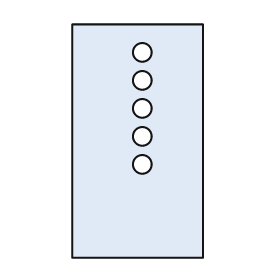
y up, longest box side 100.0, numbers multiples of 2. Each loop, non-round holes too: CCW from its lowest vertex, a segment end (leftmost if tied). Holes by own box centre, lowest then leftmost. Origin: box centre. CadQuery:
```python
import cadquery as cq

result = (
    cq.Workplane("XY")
    .moveTo(-28.0, -50.0)
    .lineTo(28.0, -50.0)
    .lineTo(28.0, 50.0)
    .lineTo(-28.0, 50.0)
    .close()
    .moveTo(2.0, -10.0)
    .circle(4.0)
    .moveTo(2.0, 2.0)
    .circle(4.0)
    .moveTo(2.0, 14.0)
    .circle(4.0)
    .moveTo(2.0, 26.0)
    .circle(4.0)
    .moveTo(2.0, 38.0)
    .circle(4.0)
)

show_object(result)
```